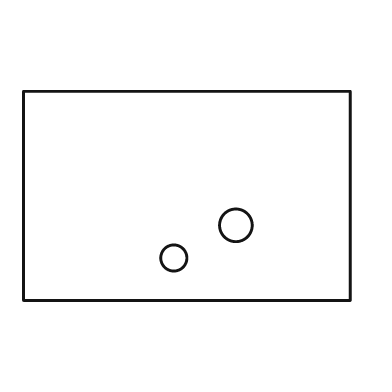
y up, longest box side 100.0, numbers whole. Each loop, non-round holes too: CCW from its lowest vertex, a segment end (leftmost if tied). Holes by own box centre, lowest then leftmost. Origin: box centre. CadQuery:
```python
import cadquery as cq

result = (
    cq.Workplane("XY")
    .moveTo(-50.0, -32.0)
    .lineTo(50.0, -32.0)
    .lineTo(50.0, 32.0)
    .lineTo(-50.0, 32.0)
    .close()
    .moveTo(-4.0, -19.0)
    .circle(4.0)
    .moveTo(15.0, -9.0)
    .circle(5.0)
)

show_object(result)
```